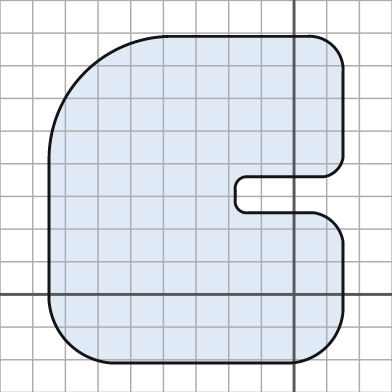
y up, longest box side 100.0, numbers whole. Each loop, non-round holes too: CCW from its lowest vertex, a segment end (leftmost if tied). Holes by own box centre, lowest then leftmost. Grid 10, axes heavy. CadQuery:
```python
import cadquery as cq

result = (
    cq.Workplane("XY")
    .moveTo(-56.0, -21.0)
    .lineTo(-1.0, -21.0)
    .threePointArc((10.0, -16.0), (15.0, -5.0))
    .lineTo(15.0, 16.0)
    .threePointArc((12.0, 22.0), (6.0, 25.0))
    .lineTo(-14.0, 25.0)
    .threePointArc((-17.0, 26.0), (-18.0, 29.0))
    .lineTo(-18.0, 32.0)
    .threePointArc((-17.0, 35.0), (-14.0, 36.0))
    .lineTo(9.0, 36.0)
    .threePointArc((13.0, 38.0), (15.0, 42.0))
    .lineTo(15.0, 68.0)
    .threePointArc((12.0, 76.0), (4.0, 79.0))
    .lineTo(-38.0, 79.0)
    .threePointArc((-64.0, 68.0), (-75.0, 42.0))
    .lineTo(-75.0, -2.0)
    .threePointArc((-69.0, -15.0), (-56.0, -21.0))
    .close()
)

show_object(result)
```